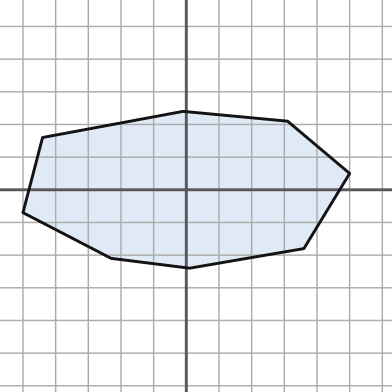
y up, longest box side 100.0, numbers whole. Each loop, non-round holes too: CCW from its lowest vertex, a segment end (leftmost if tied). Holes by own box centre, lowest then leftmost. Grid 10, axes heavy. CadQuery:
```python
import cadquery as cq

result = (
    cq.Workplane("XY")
    .moveTo(1.0, -24.0)
    .lineTo(36.0, -18.0)
    .lineTo(50.0, 5.0)
    .lineTo(31.0, 21.0)
    .lineTo(-1.0, 24.0)
    .lineTo(-44.0, 16.0)
    .lineTo(-50.0, -7.0)
    .lineTo(-23.0, -21.0)
    .close()
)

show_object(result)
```